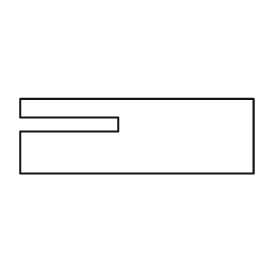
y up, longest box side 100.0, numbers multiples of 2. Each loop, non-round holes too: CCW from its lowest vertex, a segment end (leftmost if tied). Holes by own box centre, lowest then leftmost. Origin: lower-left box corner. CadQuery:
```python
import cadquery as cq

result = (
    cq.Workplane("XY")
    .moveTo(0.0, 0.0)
    .lineTo(100.0, 0.0)
    .lineTo(100.0, 32.0)
    .lineTo(0.0, 32.0)
    .lineTo(0.0, 24.0)
    .lineTo(42.0, 24.0)
    .lineTo(42.0, 18.0)
    .lineTo(0.0, 18.0)
    .close()
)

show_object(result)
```